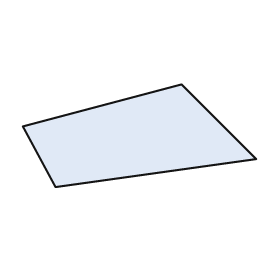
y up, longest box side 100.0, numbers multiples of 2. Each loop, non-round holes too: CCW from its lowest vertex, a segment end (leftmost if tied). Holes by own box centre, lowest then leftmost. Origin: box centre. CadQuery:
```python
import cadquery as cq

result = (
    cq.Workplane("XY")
    .moveTo(-36.0, -22.0)
    .lineTo(50.0, -10.0)
    .lineTo(18.0, 22.0)
    .lineTo(-50.0, 4.0)
    .close()
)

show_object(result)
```